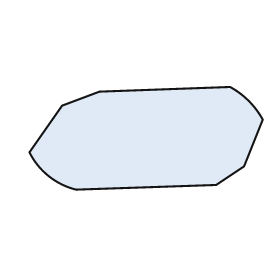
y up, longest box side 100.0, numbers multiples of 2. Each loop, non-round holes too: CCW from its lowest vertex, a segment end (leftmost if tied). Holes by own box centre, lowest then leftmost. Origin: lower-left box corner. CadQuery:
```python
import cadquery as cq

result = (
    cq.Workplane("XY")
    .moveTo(20.0, 0.0)
    .lineTo(80.0, 2.0)
    .lineTo(92.0, 10.0)
    .lineTo(100.0, 30.0)
    .threePointArc((94.0, 38.0), (86.0, 44.0))
    .lineTo(30.0, 42.0)
    .lineTo(14.0, 36.0)
    .lineTo(0.0, 16.0)
    .threePointArc((8.0, 6.0), (20.0, 0.0))
    .close()
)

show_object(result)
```